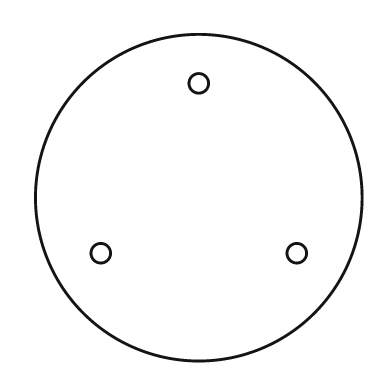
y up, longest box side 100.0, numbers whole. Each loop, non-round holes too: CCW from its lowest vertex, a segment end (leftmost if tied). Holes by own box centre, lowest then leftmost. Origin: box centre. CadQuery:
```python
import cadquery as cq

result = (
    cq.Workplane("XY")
    .moveTo(0.0, 0.0)
    .circle(50.0)
    .moveTo(-30.0, -17.0)
    .circle(3.0)
    .moveTo(30.0, -17.0)
    .circle(3.0)
    .moveTo(0.0, 35.0)
    .circle(3.0)
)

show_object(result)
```